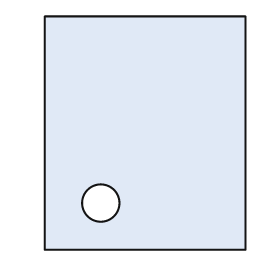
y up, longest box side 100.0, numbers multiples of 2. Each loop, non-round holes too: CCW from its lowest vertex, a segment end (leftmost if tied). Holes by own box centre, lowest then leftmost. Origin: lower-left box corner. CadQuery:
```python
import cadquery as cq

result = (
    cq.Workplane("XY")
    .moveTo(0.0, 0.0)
    .lineTo(86.0, 0.0)
    .lineTo(86.0, 100.0)
    .lineTo(0.0, 100.0)
    .close()
    .moveTo(24.0, 20.0)
    .circle(8.0)
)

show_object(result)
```